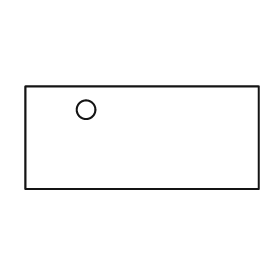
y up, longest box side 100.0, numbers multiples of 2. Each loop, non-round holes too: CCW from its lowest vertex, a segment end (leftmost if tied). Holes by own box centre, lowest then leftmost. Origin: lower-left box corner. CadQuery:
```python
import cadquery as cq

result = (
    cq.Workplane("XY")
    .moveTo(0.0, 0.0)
    .lineTo(100.0, 0.0)
    .lineTo(100.0, 44.0)
    .lineTo(0.0, 44.0)
    .close()
    .moveTo(26.0, 34.0)
    .circle(4.0)
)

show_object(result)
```